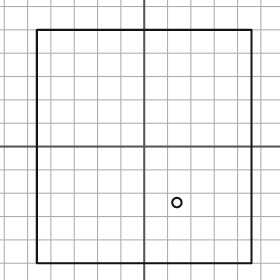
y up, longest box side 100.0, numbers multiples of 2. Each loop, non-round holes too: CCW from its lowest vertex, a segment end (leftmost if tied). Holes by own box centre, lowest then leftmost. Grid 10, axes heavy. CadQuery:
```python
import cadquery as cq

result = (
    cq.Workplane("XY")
    .moveTo(-46.0, -50.0)
    .lineTo(46.0, -50.0)
    .lineTo(46.0, 50.0)
    .lineTo(-46.0, 50.0)
    .close()
    .moveTo(14.0, -24.0)
    .circle(2.0)
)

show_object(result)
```